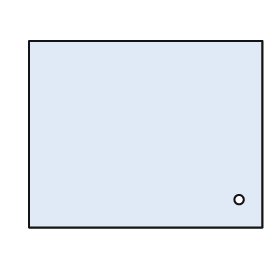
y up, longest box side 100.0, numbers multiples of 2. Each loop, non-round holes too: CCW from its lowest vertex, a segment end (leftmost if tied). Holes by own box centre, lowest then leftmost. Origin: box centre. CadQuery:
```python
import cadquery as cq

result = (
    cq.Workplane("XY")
    .moveTo(-50.0, -40.0)
    .lineTo(50.0, -40.0)
    .lineTo(50.0, 40.0)
    .lineTo(-50.0, 40.0)
    .close()
    .moveTo(40.0, -28.0)
    .circle(2.0)
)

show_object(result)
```